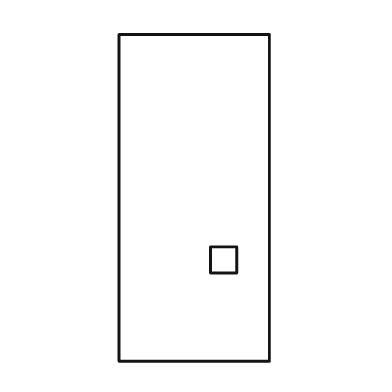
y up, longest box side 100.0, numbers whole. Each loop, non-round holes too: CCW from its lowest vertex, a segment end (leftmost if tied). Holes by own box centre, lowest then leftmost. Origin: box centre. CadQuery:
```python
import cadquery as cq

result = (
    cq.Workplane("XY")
    .moveTo(-23.0, -50.0)
    .lineTo(23.0, -50.0)
    .lineTo(23.0, 50.0)
    .lineTo(-23.0, 50.0)
    .close()
    .moveTo(5.0, -23.0)
    .lineTo(13.0, -23.0)
    .lineTo(13.0, -15.0)
    .lineTo(5.0, -15.0)
    .close()
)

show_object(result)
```